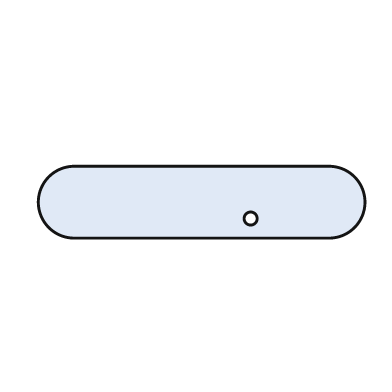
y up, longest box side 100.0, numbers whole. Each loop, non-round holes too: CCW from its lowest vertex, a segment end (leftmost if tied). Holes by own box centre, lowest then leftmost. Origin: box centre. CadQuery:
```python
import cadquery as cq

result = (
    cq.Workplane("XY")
    .moveTo(-39.0, -11.0)
    .lineTo(39.0, -11.0)
    .threePointArc((50.0, 0.0), (39.0, 11.0))
    .lineTo(-39.0, 11.0)
    .threePointArc((-50.0, 0.0), (-39.0, -11.0))
    .close()
    .moveTo(15.0, -5.0)
    .circle(2.0)
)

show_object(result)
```